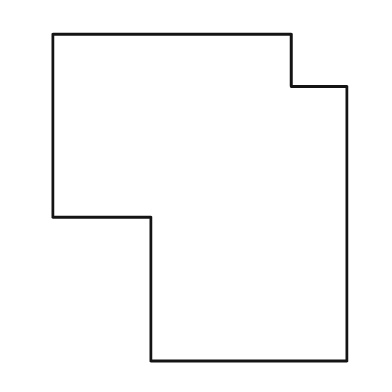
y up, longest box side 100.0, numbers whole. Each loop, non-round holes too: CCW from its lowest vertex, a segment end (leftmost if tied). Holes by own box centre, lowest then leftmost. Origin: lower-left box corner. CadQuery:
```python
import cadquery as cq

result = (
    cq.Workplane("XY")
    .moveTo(30.0, 0.0)
    .lineTo(90.0, 0.0)
    .lineTo(90.0, 84.0)
    .lineTo(73.0, 84.0)
    .lineTo(73.0, 100.0)
    .lineTo(0.0, 100.0)
    .lineTo(0.0, 44.0)
    .lineTo(30.0, 44.0)
    .close()
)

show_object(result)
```